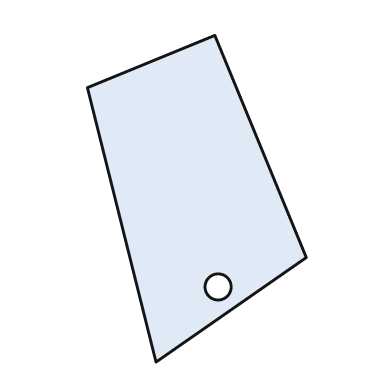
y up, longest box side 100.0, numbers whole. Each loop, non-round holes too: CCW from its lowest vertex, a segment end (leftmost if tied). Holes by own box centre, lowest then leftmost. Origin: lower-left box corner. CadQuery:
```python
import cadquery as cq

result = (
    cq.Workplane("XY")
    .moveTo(21.0, 0.0)
    .lineTo(67.0, 32.0)
    .lineTo(39.0, 100.0)
    .lineTo(0.0, 84.0)
    .close()
    .moveTo(40.0, 23.0)
    .circle(4.0)
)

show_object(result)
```